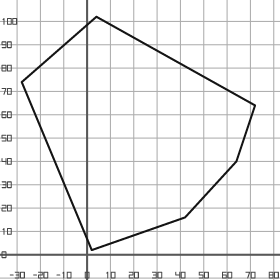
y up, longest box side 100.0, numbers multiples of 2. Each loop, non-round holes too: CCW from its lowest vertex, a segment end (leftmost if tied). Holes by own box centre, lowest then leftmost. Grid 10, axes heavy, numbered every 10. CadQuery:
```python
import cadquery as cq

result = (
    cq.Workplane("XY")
    .moveTo(2.0, 2.0)
    .lineTo(42.0, 16.0)
    .lineTo(64.0, 40.0)
    .lineTo(72.0, 64.0)
    .lineTo(4.0, 102.0)
    .lineTo(-28.0, 74.0)
    .close()
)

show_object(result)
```